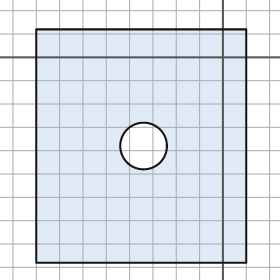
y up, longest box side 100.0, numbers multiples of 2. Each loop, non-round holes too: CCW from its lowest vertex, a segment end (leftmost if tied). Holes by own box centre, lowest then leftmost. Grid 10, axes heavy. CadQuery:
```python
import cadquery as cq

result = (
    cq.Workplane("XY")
    .moveTo(-80.0, -88.0)
    .lineTo(10.0, -88.0)
    .lineTo(10.0, 12.0)
    .lineTo(-80.0, 12.0)
    .close()
    .moveTo(-34.0, -38.0)
    .circle(10.0)
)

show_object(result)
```